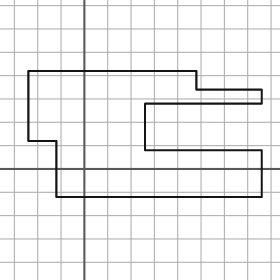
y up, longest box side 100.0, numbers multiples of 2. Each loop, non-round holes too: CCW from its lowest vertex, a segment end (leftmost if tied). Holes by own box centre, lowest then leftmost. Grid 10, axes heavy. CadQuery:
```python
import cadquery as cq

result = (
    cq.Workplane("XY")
    .moveTo(-12.0, -12.0)
    .lineTo(76.0, -12.0)
    .lineTo(76.0, 8.0)
    .lineTo(26.0, 8.0)
    .lineTo(26.0, 28.0)
    .lineTo(76.0, 28.0)
    .lineTo(76.0, 34.0)
    .lineTo(48.0, 34.0)
    .lineTo(48.0, 42.0)
    .lineTo(-24.0, 42.0)
    .lineTo(-24.0, 12.0)
    .lineTo(-12.0, 12.0)
    .close()
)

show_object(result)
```